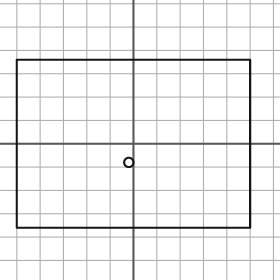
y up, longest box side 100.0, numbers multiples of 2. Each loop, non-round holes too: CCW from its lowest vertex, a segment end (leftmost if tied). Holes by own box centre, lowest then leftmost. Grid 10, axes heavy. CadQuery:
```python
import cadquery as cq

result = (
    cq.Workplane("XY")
    .moveTo(-50.0, -36.0)
    .lineTo(50.0, -36.0)
    .lineTo(50.0, 36.0)
    .lineTo(-50.0, 36.0)
    .close()
    .moveTo(-2.0, -8.0)
    .circle(2.0)
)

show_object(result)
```